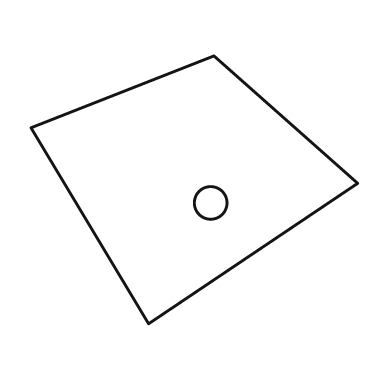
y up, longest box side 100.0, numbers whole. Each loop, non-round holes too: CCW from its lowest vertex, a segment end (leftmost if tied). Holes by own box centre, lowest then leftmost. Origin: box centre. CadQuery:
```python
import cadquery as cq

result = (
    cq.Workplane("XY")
    .moveTo(-14.0, -41.0)
    .lineTo(50.0, 2.0)
    .lineTo(6.0, 41.0)
    .lineTo(-50.0, 19.0)
    .close()
    .moveTo(5.0, -4.0)
    .circle(5.0)
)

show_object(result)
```